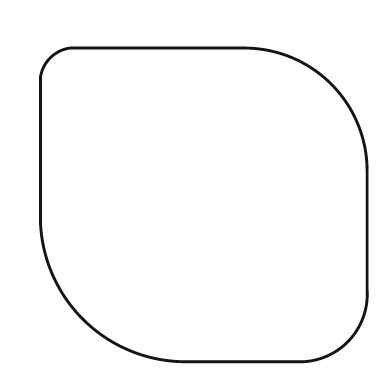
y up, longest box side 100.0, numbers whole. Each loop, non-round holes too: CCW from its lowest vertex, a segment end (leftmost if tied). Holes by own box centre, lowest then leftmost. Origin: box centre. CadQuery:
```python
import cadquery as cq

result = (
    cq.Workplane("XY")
    .moveTo(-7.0, -48.0)
    .lineTo(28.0, -48.0)
    .threePointArc((44.0, -42.0), (50.0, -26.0))
    .lineTo(50.0, 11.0)
    .threePointArc((39.0, 37.0), (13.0, 48.0))
    .lineTo(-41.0, 48.0)
    .threePointArc((-47.0, 45.0), (-50.0, 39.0))
    .lineTo(-50.0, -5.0)
    .threePointArc((-37.0, -35.0), (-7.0, -48.0))
    .close()
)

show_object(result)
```